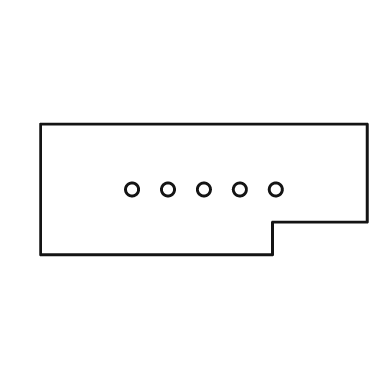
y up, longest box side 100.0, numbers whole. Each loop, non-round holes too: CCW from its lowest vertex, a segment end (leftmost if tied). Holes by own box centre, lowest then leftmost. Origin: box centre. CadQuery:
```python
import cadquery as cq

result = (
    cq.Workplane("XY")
    .moveTo(-50.0, -20.0)
    .lineTo(21.0, -20.0)
    .lineTo(21.0, -10.0)
    .lineTo(50.0, -10.0)
    .lineTo(50.0, 20.0)
    .lineTo(-50.0, 20.0)
    .close()
    .moveTo(-22.0, 0.0)
    .circle(2.0)
    .moveTo(-11.0, 0.0)
    .circle(2.0)
    .moveTo(0.0, 0.0)
    .circle(2.0)
    .moveTo(11.0, 0.0)
    .circle(2.0)
    .moveTo(22.0, 0.0)
    .circle(2.0)
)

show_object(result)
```